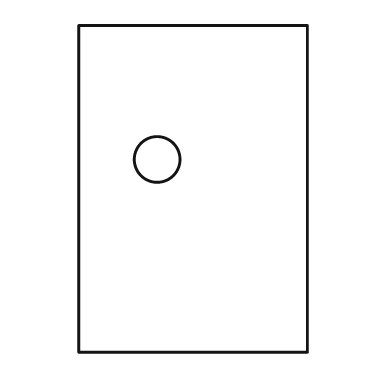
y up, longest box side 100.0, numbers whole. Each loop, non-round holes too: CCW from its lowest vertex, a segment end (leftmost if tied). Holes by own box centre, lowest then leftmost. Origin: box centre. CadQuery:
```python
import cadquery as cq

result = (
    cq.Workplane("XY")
    .moveTo(-35.0, -50.0)
    .lineTo(35.0, -50.0)
    .lineTo(35.0, 50.0)
    .lineTo(-35.0, 50.0)
    .close()
    .moveTo(-11.0, 9.0)
    .circle(7.0)
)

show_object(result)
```